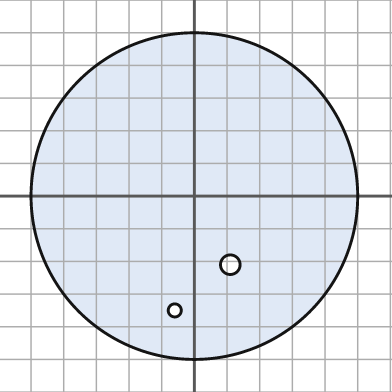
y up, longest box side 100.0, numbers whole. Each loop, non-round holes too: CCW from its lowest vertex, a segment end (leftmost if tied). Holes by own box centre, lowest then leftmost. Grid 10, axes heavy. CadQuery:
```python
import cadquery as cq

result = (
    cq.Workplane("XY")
    .moveTo(0.0, 0.0)
    .circle(50.0)
    .moveTo(-6.0, -35.0)
    .circle(2.0)
    .moveTo(11.0, -21.0)
    .circle(3.0)
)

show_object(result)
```